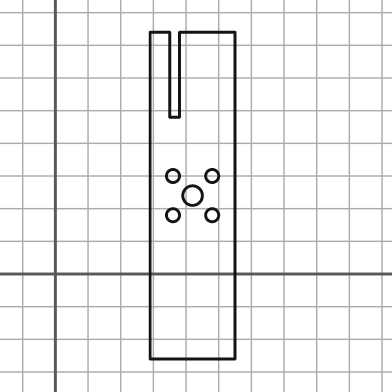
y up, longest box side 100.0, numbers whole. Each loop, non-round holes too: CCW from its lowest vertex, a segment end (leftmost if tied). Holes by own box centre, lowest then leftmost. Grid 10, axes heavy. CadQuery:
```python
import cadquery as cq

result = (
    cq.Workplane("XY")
    .moveTo(29.0, -26.0)
    .lineTo(55.0, -26.0)
    .lineTo(55.0, 74.0)
    .lineTo(38.0, 74.0)
    .lineTo(38.0, 48.0)
    .lineTo(35.0, 48.0)
    .lineTo(35.0, 74.0)
    .lineTo(29.0, 74.0)
    .close()
    .moveTo(36.0, 18.0)
    .circle(2.0)
    .moveTo(48.0, 18.0)
    .circle(2.0)
    .moveTo(42.0, 24.0)
    .circle(3.0)
    .moveTo(36.0, 30.0)
    .circle(2.0)
    .moveTo(48.0, 30.0)
    .circle(2.0)
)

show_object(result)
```